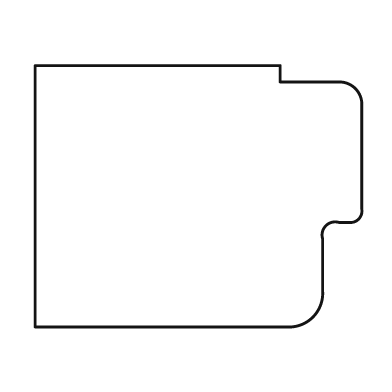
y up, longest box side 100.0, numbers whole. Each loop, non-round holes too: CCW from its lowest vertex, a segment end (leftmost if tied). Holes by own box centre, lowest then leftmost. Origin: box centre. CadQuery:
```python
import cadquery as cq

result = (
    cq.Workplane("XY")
    .moveTo(-50.0, -40.0)
    .lineTo(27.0, -40.0)
    .threePointArc((35.0, -37.0), (38.0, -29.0))
    .lineTo(38.0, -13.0)
    .threePointArc((39.0, -9.0), (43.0, -8.0))
    .lineTo(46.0, -8.0)
    .threePointArc((49.0, -7.0), (50.0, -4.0))
    .lineTo(50.0, 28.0)
    .threePointArc((48.0, 33.0), (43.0, 35.0))
    .lineTo(25.0, 35.0)
    .lineTo(25.0, 40.0)
    .lineTo(-50.0, 40.0)
    .close()
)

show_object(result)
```